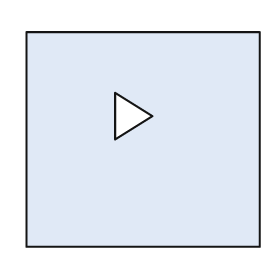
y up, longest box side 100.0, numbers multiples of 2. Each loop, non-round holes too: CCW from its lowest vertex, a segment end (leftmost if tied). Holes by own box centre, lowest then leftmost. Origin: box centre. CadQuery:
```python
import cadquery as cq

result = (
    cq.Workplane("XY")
    .moveTo(-50.0, -46.0)
    .lineTo(50.0, -46.0)
    .lineTo(50.0, 46.0)
    .lineTo(-50.0, 46.0)
    .close()
    .moveTo(-12.0, 0.0)
    .lineTo(4.0, 10.0)
    .lineTo(-12.0, 20.0)
    .close()
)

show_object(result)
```